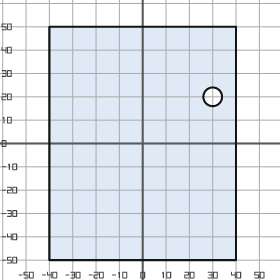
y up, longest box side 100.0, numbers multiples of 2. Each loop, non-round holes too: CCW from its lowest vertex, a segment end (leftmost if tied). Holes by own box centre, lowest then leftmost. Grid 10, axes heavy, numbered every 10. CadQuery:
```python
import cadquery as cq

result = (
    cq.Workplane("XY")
    .moveTo(-40.0, -50.0)
    .lineTo(40.0, -50.0)
    .lineTo(40.0, 50.0)
    .lineTo(-40.0, 50.0)
    .close()
    .moveTo(30.0, 20.0)
    .circle(4.0)
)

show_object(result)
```